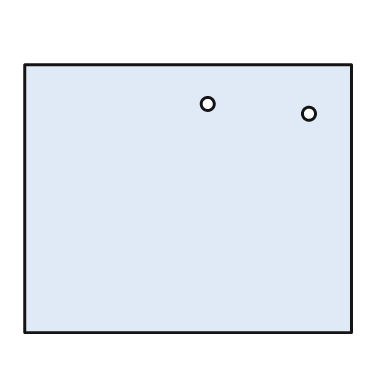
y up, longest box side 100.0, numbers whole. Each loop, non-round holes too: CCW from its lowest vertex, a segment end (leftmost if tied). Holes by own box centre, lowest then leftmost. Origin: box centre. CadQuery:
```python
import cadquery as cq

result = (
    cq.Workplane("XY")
    .moveTo(-50.0, -41.0)
    .lineTo(50.0, -41.0)
    .lineTo(50.0, 41.0)
    .lineTo(-50.0, 41.0)
    .close()
    .moveTo(37.0, 26.0)
    .circle(2.0)
    .moveTo(6.0, 29.0)
    .circle(2.0)
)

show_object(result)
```